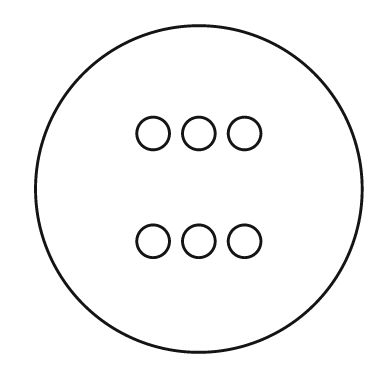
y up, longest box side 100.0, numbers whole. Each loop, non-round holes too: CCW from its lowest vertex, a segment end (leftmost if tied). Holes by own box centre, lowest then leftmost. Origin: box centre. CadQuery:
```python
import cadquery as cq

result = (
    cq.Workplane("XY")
    .moveTo(0.0, 0.0)
    .circle(50.0)
    .moveTo(-14.0, -16.0)
    .circle(5.0)
    .moveTo(0.0, -16.0)
    .circle(5.0)
    .moveTo(14.0, -16.0)
    .circle(5.0)
    .moveTo(-14.0, 17.0)
    .circle(5.0)
    .moveTo(0.0, 17.0)
    .circle(5.0)
    .moveTo(14.0, 17.0)
    .circle(5.0)
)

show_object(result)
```